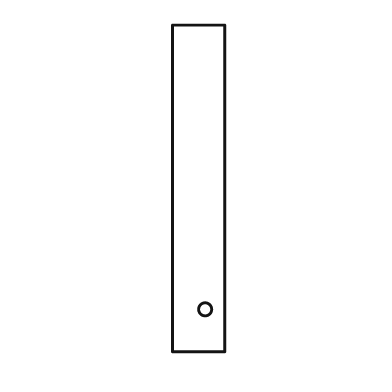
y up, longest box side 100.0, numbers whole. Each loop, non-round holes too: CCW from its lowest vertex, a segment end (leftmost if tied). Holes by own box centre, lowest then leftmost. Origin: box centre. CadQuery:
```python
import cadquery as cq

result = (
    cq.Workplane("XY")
    .moveTo(-8.0, -50.0)
    .lineTo(8.0, -50.0)
    .lineTo(8.0, 50.0)
    .lineTo(-8.0, 50.0)
    .close()
    .moveTo(2.0, -37.0)
    .circle(2.0)
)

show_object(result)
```